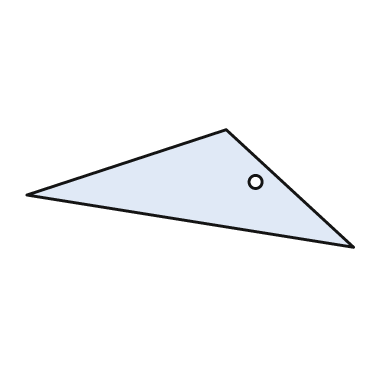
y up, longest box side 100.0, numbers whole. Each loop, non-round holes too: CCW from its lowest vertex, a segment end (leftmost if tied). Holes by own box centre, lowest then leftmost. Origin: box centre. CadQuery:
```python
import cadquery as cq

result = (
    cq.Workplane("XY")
    .moveTo(50.0, -18.0)
    .lineTo(11.0, 18.0)
    .lineTo(-50.0, -2.0)
    .close()
    .moveTo(20.0, 2.0)
    .circle(2.0)
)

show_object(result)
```